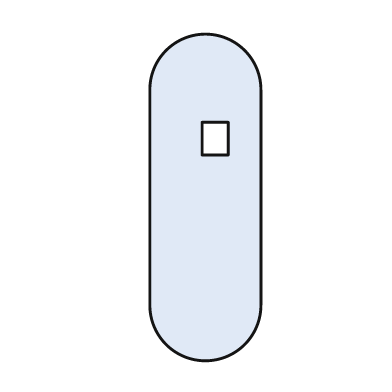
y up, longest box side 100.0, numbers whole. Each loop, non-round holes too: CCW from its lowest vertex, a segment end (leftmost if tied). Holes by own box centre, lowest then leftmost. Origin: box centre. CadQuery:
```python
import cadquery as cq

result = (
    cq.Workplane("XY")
    .moveTo(-17.0, -33.0)
    .threePointArc((0.0, -50.0), (17.0, -33.0))
    .lineTo(17.0, 33.0)
    .threePointArc((0.0, 50.0), (-17.0, 33.0))
    .close()
    .moveTo(-1.0, 13.0)
    .lineTo(7.0, 13.0)
    .lineTo(7.0, 23.0)
    .lineTo(-1.0, 23.0)
    .close()
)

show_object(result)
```